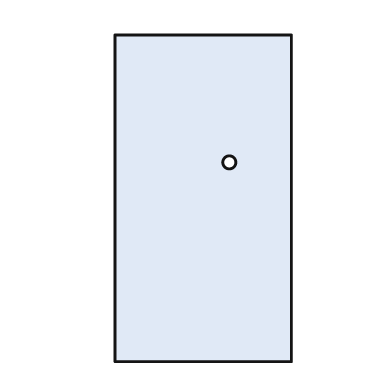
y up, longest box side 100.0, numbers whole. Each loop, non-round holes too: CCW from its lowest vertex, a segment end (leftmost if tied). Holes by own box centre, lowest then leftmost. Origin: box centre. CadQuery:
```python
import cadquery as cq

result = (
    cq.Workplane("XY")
    .moveTo(-27.0, -50.0)
    .lineTo(27.0, -50.0)
    .lineTo(27.0, 50.0)
    .lineTo(-27.0, 50.0)
    .close()
    .moveTo(8.0, 11.0)
    .circle(2.0)
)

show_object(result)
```